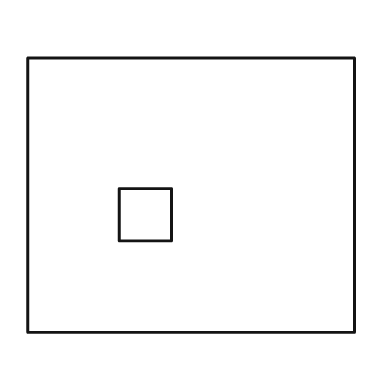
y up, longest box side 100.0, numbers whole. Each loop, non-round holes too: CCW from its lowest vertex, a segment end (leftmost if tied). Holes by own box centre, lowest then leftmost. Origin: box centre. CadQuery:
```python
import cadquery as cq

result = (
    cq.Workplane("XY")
    .moveTo(-50.0, -42.0)
    .lineTo(50.0, -42.0)
    .lineTo(50.0, 42.0)
    .lineTo(-50.0, 42.0)
    .close()
    .moveTo(-22.0, -14.0)
    .lineTo(-6.0, -14.0)
    .lineTo(-6.0, 2.0)
    .lineTo(-22.0, 2.0)
    .close()
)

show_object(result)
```